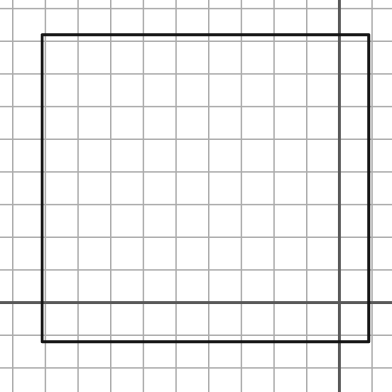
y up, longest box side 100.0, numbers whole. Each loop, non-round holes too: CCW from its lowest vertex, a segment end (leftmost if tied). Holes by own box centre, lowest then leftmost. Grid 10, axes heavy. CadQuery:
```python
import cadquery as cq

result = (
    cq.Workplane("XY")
    .moveTo(-91.0, -12.0)
    .lineTo(9.0, -12.0)
    .lineTo(9.0, 82.0)
    .lineTo(-91.0, 82.0)
    .close()
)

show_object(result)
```